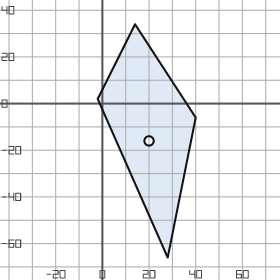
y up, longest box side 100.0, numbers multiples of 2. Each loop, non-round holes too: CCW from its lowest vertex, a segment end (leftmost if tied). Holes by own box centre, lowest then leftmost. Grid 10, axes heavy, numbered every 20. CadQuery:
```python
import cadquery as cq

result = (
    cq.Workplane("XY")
    .moveTo(28.0, -66.0)
    .lineTo(40.0, -6.0)
    .lineTo(14.0, 34.0)
    .lineTo(-2.0, 2.0)
    .close()
    .moveTo(20.0, -16.0)
    .circle(2.0)
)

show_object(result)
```